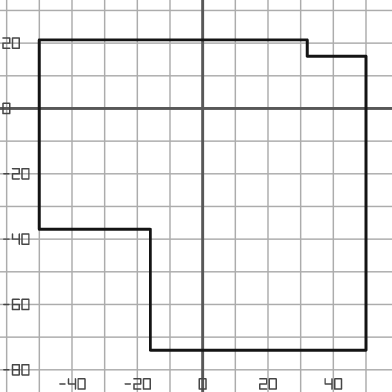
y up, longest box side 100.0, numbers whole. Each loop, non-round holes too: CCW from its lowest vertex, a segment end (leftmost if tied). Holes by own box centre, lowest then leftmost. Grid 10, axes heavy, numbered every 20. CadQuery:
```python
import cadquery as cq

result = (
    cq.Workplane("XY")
    .moveTo(-16.0, -74.0)
    .lineTo(50.0, -74.0)
    .lineTo(50.0, 16.0)
    .lineTo(32.0, 16.0)
    .lineTo(32.0, 21.0)
    .lineTo(-50.0, 21.0)
    .lineTo(-50.0, -37.0)
    .lineTo(-16.0, -37.0)
    .close()
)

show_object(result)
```